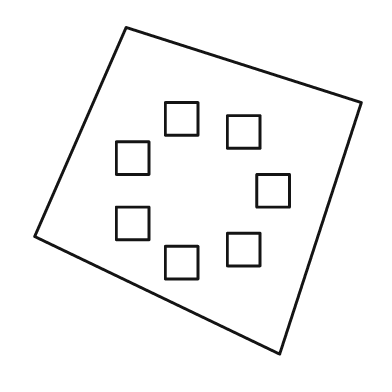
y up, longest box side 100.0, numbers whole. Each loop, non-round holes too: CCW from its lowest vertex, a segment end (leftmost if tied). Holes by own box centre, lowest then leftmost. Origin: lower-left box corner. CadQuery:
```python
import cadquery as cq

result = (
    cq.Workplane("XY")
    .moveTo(75.0, 0.0)
    .lineTo(100.0, 77.0)
    .lineTo(28.0, 100.0)
    .lineTo(0.0, 36.0)
    .close()
    .moveTo(40.0, 23.0)
    .lineTo(50.0, 23.0)
    .lineTo(50.0, 33.0)
    .lineTo(40.0, 33.0)
    .close()
    .moveTo(59.0, 27.0)
    .lineTo(69.0, 27.0)
    .lineTo(69.0, 37.0)
    .lineTo(59.0, 37.0)
    .close()
    .moveTo(25.0, 35.0)
    .lineTo(35.0, 35.0)
    .lineTo(35.0, 45.0)
    .lineTo(25.0, 45.0)
    .close()
    .moveTo(68.0, 45.0)
    .lineTo(78.0, 45.0)
    .lineTo(78.0, 55.0)
    .lineTo(68.0, 55.0)
    .close()
    .moveTo(25.0, 55.0)
    .lineTo(35.0, 55.0)
    .lineTo(35.0, 65.0)
    .lineTo(25.0, 65.0)
    .close()
    .moveTo(59.0, 63.0)
    .lineTo(69.0, 63.0)
    .lineTo(69.0, 73.0)
    .lineTo(59.0, 73.0)
    .close()
    .moveTo(40.0, 67.0)
    .lineTo(50.0, 67.0)
    .lineTo(50.0, 77.0)
    .lineTo(40.0, 77.0)
    .close()
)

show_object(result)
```